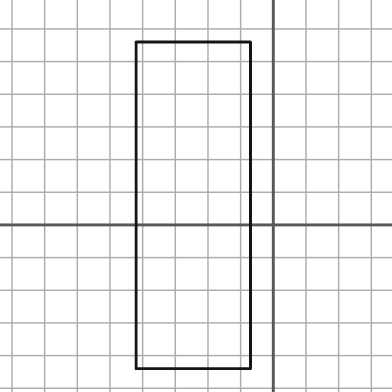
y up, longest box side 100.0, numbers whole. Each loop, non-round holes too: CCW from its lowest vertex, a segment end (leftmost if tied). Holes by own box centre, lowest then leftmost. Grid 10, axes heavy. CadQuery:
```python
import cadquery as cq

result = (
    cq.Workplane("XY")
    .moveTo(-42.0, -44.0)
    .lineTo(-7.0, -44.0)
    .lineTo(-7.0, 56.0)
    .lineTo(-42.0, 56.0)
    .close()
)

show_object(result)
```